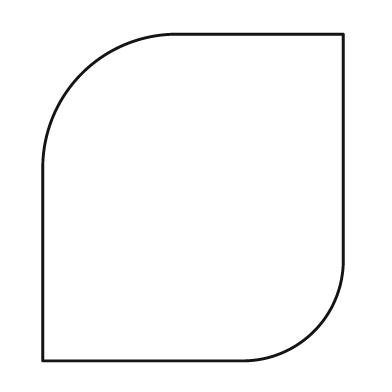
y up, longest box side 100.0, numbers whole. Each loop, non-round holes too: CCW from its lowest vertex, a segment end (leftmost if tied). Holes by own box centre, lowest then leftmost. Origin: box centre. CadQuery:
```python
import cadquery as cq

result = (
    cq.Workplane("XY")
    .moveTo(-46.0, -50.0)
    .lineTo(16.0, -50.0)
    .threePointArc((37.0, -41.0), (46.0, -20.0))
    .lineTo(46.0, 50.0)
    .lineTo(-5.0, 50.0)
    .threePointArc((-34.0, 38.0), (-46.0, 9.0))
    .close()
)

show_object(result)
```